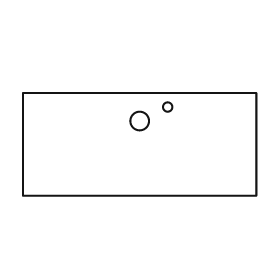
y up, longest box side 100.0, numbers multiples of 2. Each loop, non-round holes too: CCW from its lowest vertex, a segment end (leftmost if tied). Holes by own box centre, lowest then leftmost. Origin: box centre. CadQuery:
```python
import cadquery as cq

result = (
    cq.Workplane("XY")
    .moveTo(-50.0, -22.0)
    .lineTo(50.0, -22.0)
    .lineTo(50.0, 22.0)
    .lineTo(-50.0, 22.0)
    .close()
    .moveTo(0.0, 10.0)
    .circle(4.0)
    .moveTo(12.0, 16.0)
    .circle(2.0)
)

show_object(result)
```